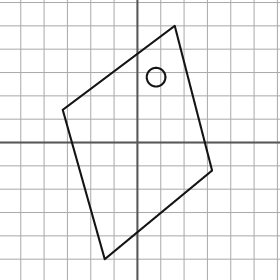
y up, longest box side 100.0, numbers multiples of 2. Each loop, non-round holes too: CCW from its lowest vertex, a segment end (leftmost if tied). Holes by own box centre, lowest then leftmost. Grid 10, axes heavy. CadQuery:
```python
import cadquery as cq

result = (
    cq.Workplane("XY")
    .moveTo(-14.0, -50.0)
    .lineTo(32.0, -12.0)
    .lineTo(16.0, 50.0)
    .lineTo(-32.0, 14.0)
    .close()
    .moveTo(8.0, 28.0)
    .circle(4.0)
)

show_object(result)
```